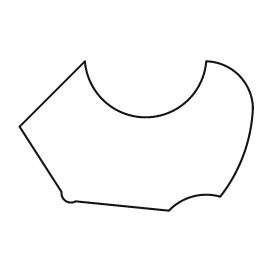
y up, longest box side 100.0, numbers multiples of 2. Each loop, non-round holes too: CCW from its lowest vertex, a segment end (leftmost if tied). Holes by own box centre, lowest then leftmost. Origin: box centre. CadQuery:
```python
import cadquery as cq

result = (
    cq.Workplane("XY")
    .moveTo(14.0, -32.0)
    .threePointArc((24.0, -26.0), (36.0, -26.0))
    .threePointArc((46.0, -8.0), (50.0, 12.0))
    .threePointArc((44.0, 26.0), (30.0, 32.0))
    .threePointArc((4.0, 8.0), (-22.0, 32.0))
    .lineTo(-50.0, 4.0)
    .lineTo(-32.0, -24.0)
    .threePointArc((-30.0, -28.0), (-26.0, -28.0))
    .close()
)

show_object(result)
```